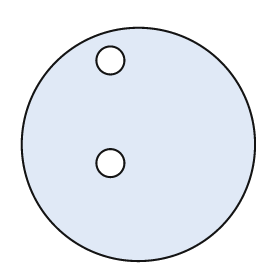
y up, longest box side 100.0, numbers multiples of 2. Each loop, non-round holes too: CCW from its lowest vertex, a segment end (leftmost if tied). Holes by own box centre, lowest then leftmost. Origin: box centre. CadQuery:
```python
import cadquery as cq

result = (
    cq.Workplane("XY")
    .moveTo(0.0, 0.0)
    .circle(50.0)
    .moveTo(-12.0, -8.0)
    .circle(6.0)
    .moveTo(-12.0, 36.0)
    .circle(6.0)
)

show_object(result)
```